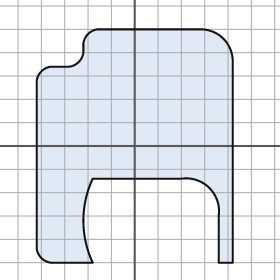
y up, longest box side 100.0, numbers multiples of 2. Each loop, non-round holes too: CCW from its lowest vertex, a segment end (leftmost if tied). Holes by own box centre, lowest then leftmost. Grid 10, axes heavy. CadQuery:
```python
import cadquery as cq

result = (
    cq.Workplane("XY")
    .moveTo(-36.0, -50.0)
    .lineTo(-18.0, -50.0)
    .threePointArc((-22.0, -32.0), (-18.0, -14.0))
    .lineTo(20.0, -14.0)
    .threePointArc((32.0, -18.0), (36.0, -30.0))
    .lineTo(36.0, -50.0)
    .lineTo(42.0, -50.0)
    .lineTo(42.0, 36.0)
    .threePointArc((38.0, 46.0), (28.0, 50.0))
    .lineTo(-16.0, 50.0)
    .threePointArc((-20.0, 48.0), (-22.0, 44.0))
    .lineTo(-22.0, 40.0)
    .threePointArc((-24.0, 36.0), (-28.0, 34.0))
    .lineTo(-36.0, 34.0)
    .threePointArc((-40.0, 32.0), (-42.0, 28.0))
    .lineTo(-42.0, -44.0)
    .threePointArc((-40.0, -48.0), (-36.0, -50.0))
    .close()
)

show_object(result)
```